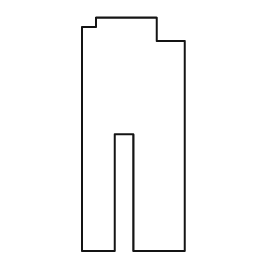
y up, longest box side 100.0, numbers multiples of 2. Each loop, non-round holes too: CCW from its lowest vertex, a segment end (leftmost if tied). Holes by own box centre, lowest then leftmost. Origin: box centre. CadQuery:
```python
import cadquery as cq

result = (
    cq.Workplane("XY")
    .moveTo(-22.0, -50.0)
    .lineTo(-8.0, -50.0)
    .lineTo(-8.0, 0.0)
    .lineTo(0.0, 0.0)
    .lineTo(0.0, -50.0)
    .lineTo(22.0, -50.0)
    .lineTo(22.0, 40.0)
    .lineTo(10.0, 40.0)
    .lineTo(10.0, 50.0)
    .lineTo(-16.0, 50.0)
    .lineTo(-16.0, 46.0)
    .lineTo(-22.0, 46.0)
    .close()
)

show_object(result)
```